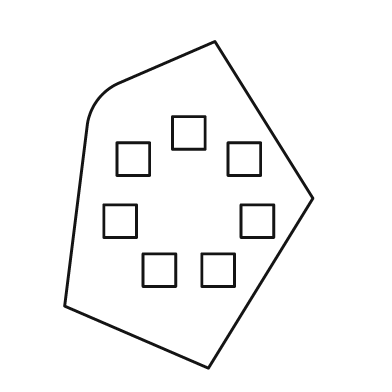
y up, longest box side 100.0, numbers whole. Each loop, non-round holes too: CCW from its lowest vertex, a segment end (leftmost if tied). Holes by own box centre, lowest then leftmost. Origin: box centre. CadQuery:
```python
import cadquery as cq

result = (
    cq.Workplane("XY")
    .moveTo(6.0, -50.0)
    .lineTo(38.0, 2.0)
    .lineTo(8.0, 50.0)
    .lineTo(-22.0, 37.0)
    .threePointArc((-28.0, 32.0), (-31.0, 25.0))
    .lineTo(-38.0, -31.0)
    .close()
    .moveTo(-14.0, -25.0)
    .lineTo(-4.0, -25.0)
    .lineTo(-4.0, -15.0)
    .lineTo(-14.0, -15.0)
    .close()
    .moveTo(4.0, -25.0)
    .lineTo(14.0, -25.0)
    .lineTo(14.0, -15.0)
    .lineTo(4.0, -15.0)
    .close()
    .moveTo(-26.0, -10.0)
    .lineTo(-16.0, -10.0)
    .lineTo(-16.0, 0.0)
    .lineTo(-26.0, 0.0)
    .close()
    .moveTo(16.0, -10.0)
    .lineTo(26.0, -10.0)
    .lineTo(26.0, 0.0)
    .lineTo(16.0, 0.0)
    .close()
    .moveTo(-22.0, 9.0)
    .lineTo(-12.0, 9.0)
    .lineTo(-12.0, 19.0)
    .lineTo(-22.0, 19.0)
    .close()
    .moveTo(12.0, 9.0)
    .lineTo(22.0, 9.0)
    .lineTo(22.0, 19.0)
    .lineTo(12.0, 19.0)
    .close()
    .moveTo(-5.0, 17.0)
    .lineTo(5.0, 17.0)
    .lineTo(5.0, 27.0)
    .lineTo(-5.0, 27.0)
    .close()
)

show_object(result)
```